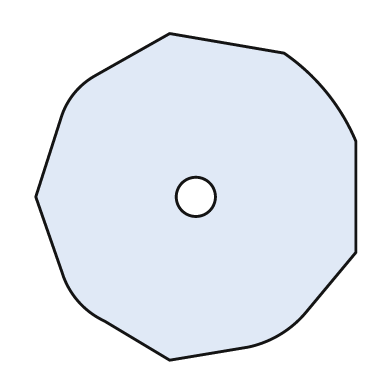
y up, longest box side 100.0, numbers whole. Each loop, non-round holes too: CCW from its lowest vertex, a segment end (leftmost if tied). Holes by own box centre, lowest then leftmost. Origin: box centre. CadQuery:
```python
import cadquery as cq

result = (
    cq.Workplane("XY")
    .moveTo(-8.0, -50.0)
    .lineTo(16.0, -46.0)
    .threePointArc((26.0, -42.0), (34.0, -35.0))
    .lineTo(49.0, -17.0)
    .lineTo(49.0, 17.0)
    .threePointArc((40.0, 32.0), (27.0, 44.0))
    .lineTo(-8.0, 50.0)
    .lineTo(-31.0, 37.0)
    .threePointArc((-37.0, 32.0), (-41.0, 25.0))
    .lineTo(-49.0, 0.0)
    .lineTo(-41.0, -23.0)
    .threePointArc((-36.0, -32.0), (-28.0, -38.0))
    .close()
    .moveTo(0.0, 0.0)
    .circle(6.0)
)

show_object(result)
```